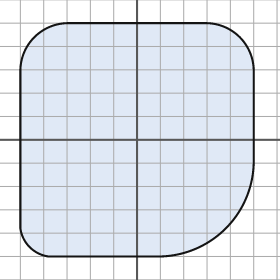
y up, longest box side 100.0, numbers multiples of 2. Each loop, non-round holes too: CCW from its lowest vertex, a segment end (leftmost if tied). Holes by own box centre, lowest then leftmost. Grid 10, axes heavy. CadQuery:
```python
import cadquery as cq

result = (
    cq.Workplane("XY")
    .moveTo(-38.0, -50.0)
    .lineTo(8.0, -50.0)
    .threePointArc((38.0, -38.0), (50.0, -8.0))
    .lineTo(50.0, 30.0)
    .threePointArc((44.0, 44.0), (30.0, 50.0))
    .lineTo(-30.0, 50.0)
    .threePointArc((-44.0, 44.0), (-50.0, 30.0))
    .lineTo(-50.0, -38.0)
    .threePointArc((-46.0, -46.0), (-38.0, -50.0))
    .close()
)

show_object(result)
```